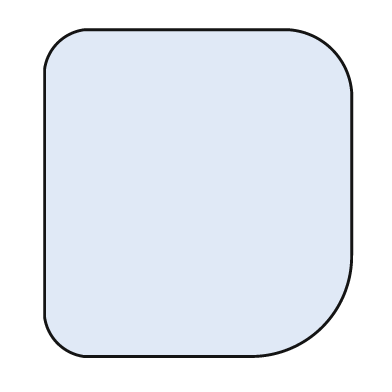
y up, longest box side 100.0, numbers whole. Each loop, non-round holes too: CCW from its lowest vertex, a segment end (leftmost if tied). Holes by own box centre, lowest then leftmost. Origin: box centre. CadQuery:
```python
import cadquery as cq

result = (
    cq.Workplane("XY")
    .moveTo(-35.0, -50.0)
    .lineTo(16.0, -50.0)
    .threePointArc((38.0, -41.0), (47.0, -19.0))
    .lineTo(47.0, 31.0)
    .threePointArc((41.0, 44.0), (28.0, 50.0))
    .lineTo(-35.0, 50.0)
    .threePointArc((-43.0, 46.0), (-47.0, 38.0))
    .lineTo(-47.0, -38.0)
    .threePointArc((-43.0, -46.0), (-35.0, -50.0))
    .close()
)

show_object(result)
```